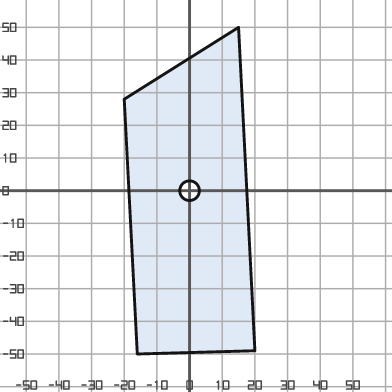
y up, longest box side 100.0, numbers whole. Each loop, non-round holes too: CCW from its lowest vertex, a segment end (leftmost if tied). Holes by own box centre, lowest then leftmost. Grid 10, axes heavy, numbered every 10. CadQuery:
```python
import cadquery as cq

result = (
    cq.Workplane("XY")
    .moveTo(-16.0, -50.0)
    .lineTo(20.0, -49.0)
    .lineTo(15.0, 50.0)
    .lineTo(-20.0, 28.0)
    .close()
    .moveTo(0.0, 0.0)
    .circle(3.0)
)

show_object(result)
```